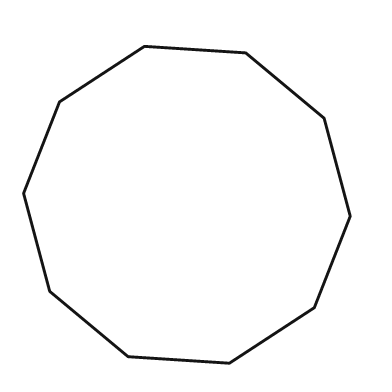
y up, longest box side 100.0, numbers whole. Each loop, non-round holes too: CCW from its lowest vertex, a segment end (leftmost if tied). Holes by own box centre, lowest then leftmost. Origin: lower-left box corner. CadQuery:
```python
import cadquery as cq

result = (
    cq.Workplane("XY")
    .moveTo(63.0, 0.0)
    .lineTo(89.0, 17.0)
    .lineTo(100.0, 45.0)
    .lineTo(92.0, 75.0)
    .lineTo(68.0, 95.0)
    .lineTo(37.0, 97.0)
    .lineTo(11.0, 80.0)
    .lineTo(0.0, 52.0)
    .lineTo(8.0, 22.0)
    .lineTo(32.0, 2.0)
    .close()
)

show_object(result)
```